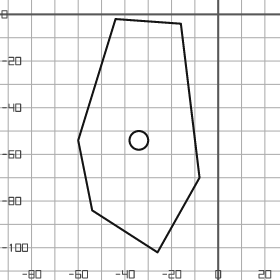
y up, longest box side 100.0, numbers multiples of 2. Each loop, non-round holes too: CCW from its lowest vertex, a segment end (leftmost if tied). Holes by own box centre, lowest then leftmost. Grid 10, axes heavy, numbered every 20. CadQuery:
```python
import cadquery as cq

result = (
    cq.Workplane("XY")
    .moveTo(-26.0, -102.0)
    .lineTo(-8.0, -70.0)
    .lineTo(-16.0, -4.0)
    .lineTo(-44.0, -2.0)
    .lineTo(-60.0, -54.0)
    .lineTo(-54.0, -84.0)
    .close()
    .moveTo(-34.0, -54.0)
    .circle(4.0)
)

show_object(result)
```